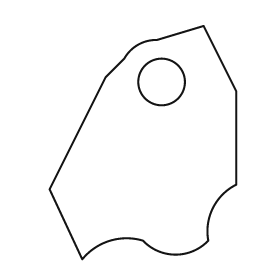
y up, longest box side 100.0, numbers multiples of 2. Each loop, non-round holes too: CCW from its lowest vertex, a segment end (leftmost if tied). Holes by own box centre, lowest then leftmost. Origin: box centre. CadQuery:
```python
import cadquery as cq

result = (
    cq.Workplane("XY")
    .moveTo(-26.0, -50.0)
    .threePointArc((-14.0, -42.0), (0.0, -42.0))
    .threePointArc((14.0, -48.0), (28.0, -42.0))
    .threePointArc((30.0, -28.0), (40.0, -18.0))
    .lineTo(40.0, 22.0)
    .lineTo(26.0, 50.0)
    .lineTo(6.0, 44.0)
    .threePointArc((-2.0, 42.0), (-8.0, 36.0))
    .lineTo(-16.0, 28.0)
    .lineTo(-40.0, -20.0)
    .close()
    .moveTo(8.0, 26.0)
    .circle(10.0)
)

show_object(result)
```